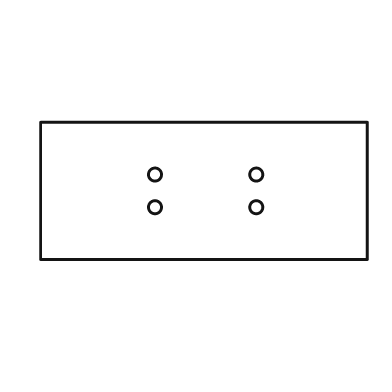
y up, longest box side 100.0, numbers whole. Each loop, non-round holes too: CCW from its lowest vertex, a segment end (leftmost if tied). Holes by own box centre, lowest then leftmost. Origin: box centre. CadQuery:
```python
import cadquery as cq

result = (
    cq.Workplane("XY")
    .moveTo(-50.0, -21.0)
    .lineTo(50.0, -21.0)
    .lineTo(50.0, 21.0)
    .lineTo(-50.0, 21.0)
    .close()
    .moveTo(-15.0, -5.0)
    .circle(2.0)
    .moveTo(16.0, -5.0)
    .circle(2.0)
    .moveTo(-15.0, 5.0)
    .circle(2.0)
    .moveTo(16.0, 5.0)
    .circle(2.0)
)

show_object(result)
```